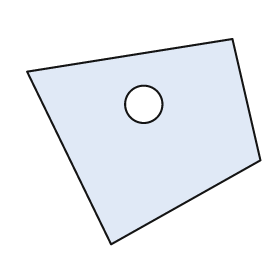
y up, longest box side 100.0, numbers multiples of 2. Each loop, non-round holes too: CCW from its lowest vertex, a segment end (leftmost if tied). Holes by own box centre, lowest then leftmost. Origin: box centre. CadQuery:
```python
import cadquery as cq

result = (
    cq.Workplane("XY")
    .moveTo(-14.0, -44.0)
    .lineTo(50.0, -8.0)
    .lineTo(38.0, 44.0)
    .lineTo(-50.0, 30.0)
    .close()
    .moveTo(0.0, 16.0)
    .circle(8.0)
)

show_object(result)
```